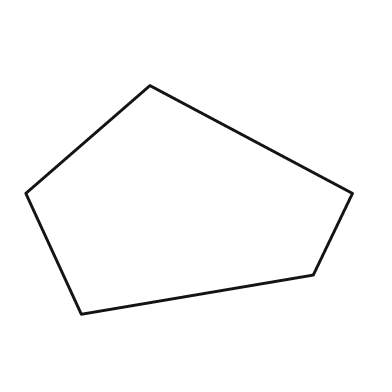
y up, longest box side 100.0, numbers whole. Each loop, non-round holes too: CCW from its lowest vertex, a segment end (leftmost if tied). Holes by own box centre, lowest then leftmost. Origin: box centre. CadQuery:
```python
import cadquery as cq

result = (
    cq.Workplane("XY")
    .moveTo(-33.0, -35.0)
    .lineTo(38.0, -23.0)
    .lineTo(50.0, 2.0)
    .lineTo(-12.0, 35.0)
    .lineTo(-50.0, 2.0)
    .close()
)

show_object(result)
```